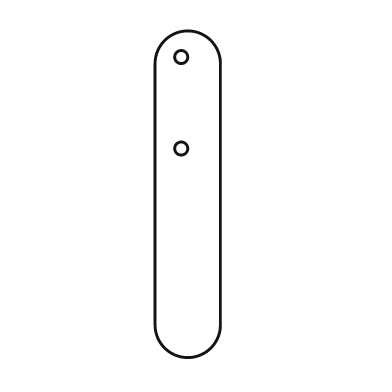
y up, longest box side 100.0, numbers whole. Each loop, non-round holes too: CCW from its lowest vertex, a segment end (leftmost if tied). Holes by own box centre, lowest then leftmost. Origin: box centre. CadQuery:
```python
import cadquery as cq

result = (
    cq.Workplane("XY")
    .moveTo(-10.0, -40.0)
    .threePointArc((0.0, -50.0), (10.0, -40.0))
    .lineTo(10.0, 40.0)
    .threePointArc((0.0, 50.0), (-10.0, 40.0))
    .close()
    .moveTo(-2.0, 14.0)
    .circle(2.0)
    .moveTo(-2.0, 42.0)
    .circle(2.0)
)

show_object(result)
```